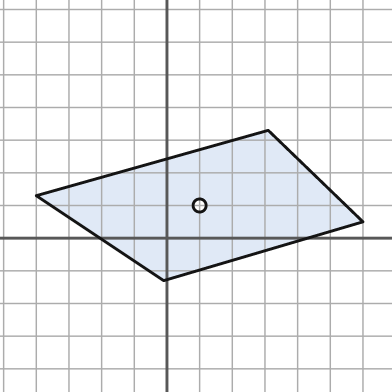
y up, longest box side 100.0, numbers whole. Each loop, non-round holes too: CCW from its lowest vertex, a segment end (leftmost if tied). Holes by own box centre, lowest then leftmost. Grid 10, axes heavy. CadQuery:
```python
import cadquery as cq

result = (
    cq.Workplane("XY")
    .moveTo(-1.0, -13.0)
    .lineTo(60.0, 5.0)
    .lineTo(31.0, 33.0)
    .lineTo(-40.0, 13.0)
    .close()
    .moveTo(10.0, 10.0)
    .circle(2.0)
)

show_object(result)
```